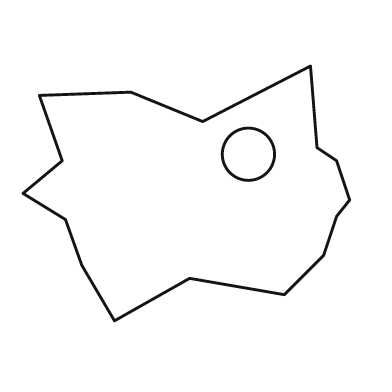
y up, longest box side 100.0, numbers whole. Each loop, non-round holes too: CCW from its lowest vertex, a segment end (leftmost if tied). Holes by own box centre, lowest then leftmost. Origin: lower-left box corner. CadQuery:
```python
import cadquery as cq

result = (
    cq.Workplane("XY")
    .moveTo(28.0, 0.0)
    .lineTo(51.0, 13.0)
    .lineTo(80.0, 8.0)
    .lineTo(92.0, 20.0)
    .lineTo(96.0, 32.0)
    .lineTo(100.0, 37.0)
    .lineTo(96.0, 49.0)
    .lineTo(90.0, 53.0)
    .lineTo(88.0, 78.0)
    .lineTo(55.0, 61.0)
    .lineTo(33.0, 70.0)
    .lineTo(5.0, 69.0)
    .lineTo(12.0, 49.0)
    .lineTo(0.0, 39.0)
    .lineTo(13.0, 31.0)
    .lineTo(18.0, 17.0)
    .close()
    .moveTo(69.0, 51.0)
    .circle(8.0)
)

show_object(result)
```